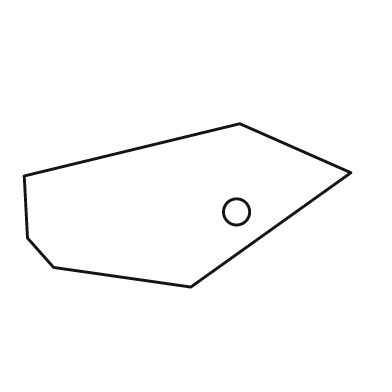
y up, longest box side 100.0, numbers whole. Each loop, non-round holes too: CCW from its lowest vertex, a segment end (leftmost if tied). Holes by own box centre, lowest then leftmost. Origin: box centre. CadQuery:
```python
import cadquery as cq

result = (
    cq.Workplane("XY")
    .moveTo(1.0, -25.0)
    .lineTo(50.0, 10.0)
    .lineTo(16.0, 25.0)
    .lineTo(-50.0, 9.0)
    .lineTo(-49.0, -10.0)
    .lineTo(-41.0, -19.0)
    .close()
    .moveTo(15.0, -2.0)
    .circle(4.0)
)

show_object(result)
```